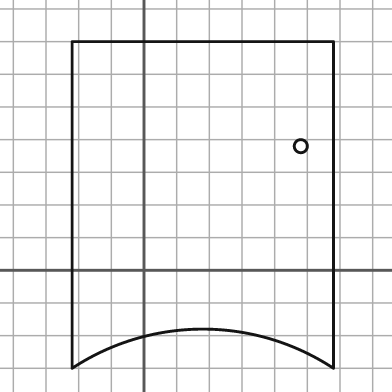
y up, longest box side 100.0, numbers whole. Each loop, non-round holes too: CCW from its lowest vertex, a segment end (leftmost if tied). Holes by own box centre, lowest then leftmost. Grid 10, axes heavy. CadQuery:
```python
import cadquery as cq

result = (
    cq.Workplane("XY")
    .moveTo(-22.0, -30.0)
    .threePointArc((18.0, -18.0), (58.0, -30.0))
    .lineTo(58.0, 70.0)
    .lineTo(-22.0, 70.0)
    .close()
    .moveTo(48.0, 38.0)
    .circle(2.0)
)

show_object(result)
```